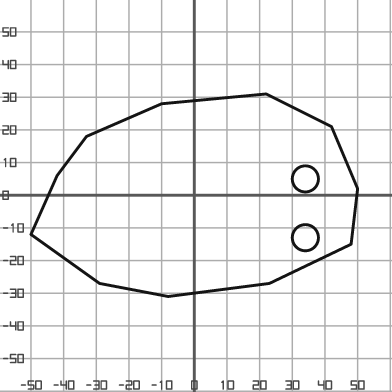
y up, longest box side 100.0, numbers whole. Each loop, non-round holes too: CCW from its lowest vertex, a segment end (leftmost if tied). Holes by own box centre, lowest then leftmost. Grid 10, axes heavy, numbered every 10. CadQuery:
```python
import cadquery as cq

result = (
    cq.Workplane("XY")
    .moveTo(-8.0, -31.0)
    .lineTo(23.0, -27.0)
    .lineTo(48.0, -15.0)
    .lineTo(50.0, 2.0)
    .lineTo(42.0, 21.0)
    .lineTo(22.0, 31.0)
    .lineTo(-10.0, 28.0)
    .lineTo(-33.0, 18.0)
    .lineTo(-42.0, 6.0)
    .lineTo(-50.0, -12.0)
    .lineTo(-29.0, -27.0)
    .close()
    .moveTo(34.0, -13.0)
    .circle(4.0)
    .moveTo(34.0, 5.0)
    .circle(4.0)
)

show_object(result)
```